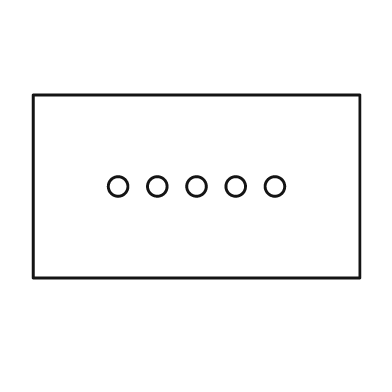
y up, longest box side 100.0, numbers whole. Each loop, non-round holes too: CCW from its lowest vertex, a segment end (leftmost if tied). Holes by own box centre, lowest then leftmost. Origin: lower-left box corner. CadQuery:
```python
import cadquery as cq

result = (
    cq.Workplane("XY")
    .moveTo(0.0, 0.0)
    .lineTo(100.0, 0.0)
    .lineTo(100.0, 56.0)
    .lineTo(0.0, 56.0)
    .close()
    .moveTo(26.0, 28.0)
    .circle(3.0)
    .moveTo(38.0, 28.0)
    .circle(3.0)
    .moveTo(50.0, 28.0)
    .circle(3.0)
    .moveTo(62.0, 28.0)
    .circle(3.0)
    .moveTo(74.0, 28.0)
    .circle(3.0)
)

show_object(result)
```